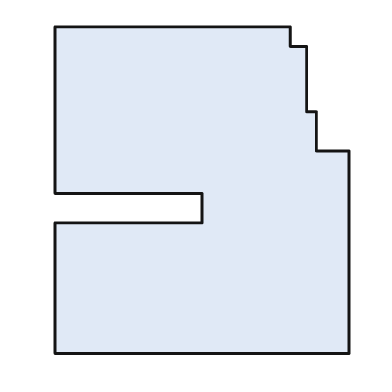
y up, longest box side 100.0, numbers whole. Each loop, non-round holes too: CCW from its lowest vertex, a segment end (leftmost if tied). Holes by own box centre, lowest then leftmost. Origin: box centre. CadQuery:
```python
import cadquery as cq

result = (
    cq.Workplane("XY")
    .moveTo(-45.0, -50.0)
    .lineTo(45.0, -50.0)
    .lineTo(45.0, 12.0)
    .lineTo(35.0, 12.0)
    .lineTo(35.0, 24.0)
    .lineTo(32.0, 24.0)
    .lineTo(32.0, 44.0)
    .lineTo(27.0, 44.0)
    .lineTo(27.0, 50.0)
    .lineTo(-45.0, 50.0)
    .lineTo(-45.0, -1.0)
    .lineTo(0.0, -1.0)
    .lineTo(0.0, -10.0)
    .lineTo(-45.0, -10.0)
    .close()
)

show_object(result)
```